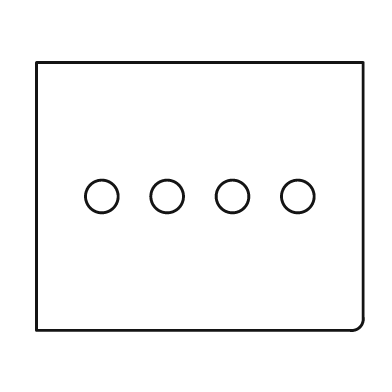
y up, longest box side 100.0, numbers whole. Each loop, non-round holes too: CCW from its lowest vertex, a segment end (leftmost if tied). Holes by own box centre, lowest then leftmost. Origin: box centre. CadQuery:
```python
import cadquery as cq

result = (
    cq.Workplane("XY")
    .moveTo(-50.0, -41.0)
    .lineTo(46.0, -41.0)
    .threePointArc((49.0, -40.0), (50.0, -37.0))
    .lineTo(50.0, 41.0)
    .lineTo(-50.0, 41.0)
    .close()
    .moveTo(-30.0, 0.0)
    .circle(5.0)
    .moveTo(-10.0, 0.0)
    .circle(5.0)
    .moveTo(10.0, 0.0)
    .circle(5.0)
    .moveTo(30.0, 0.0)
    .circle(5.0)
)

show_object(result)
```